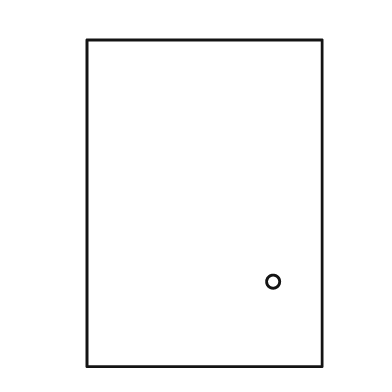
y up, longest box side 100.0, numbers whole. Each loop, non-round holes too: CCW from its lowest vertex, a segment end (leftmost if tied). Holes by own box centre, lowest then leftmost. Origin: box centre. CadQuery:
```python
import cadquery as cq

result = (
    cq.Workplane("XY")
    .moveTo(-36.0, -50.0)
    .lineTo(36.0, -50.0)
    .lineTo(36.0, 50.0)
    .lineTo(-36.0, 50.0)
    .close()
    .moveTo(21.0, -24.0)
    .circle(2.0)
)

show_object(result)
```